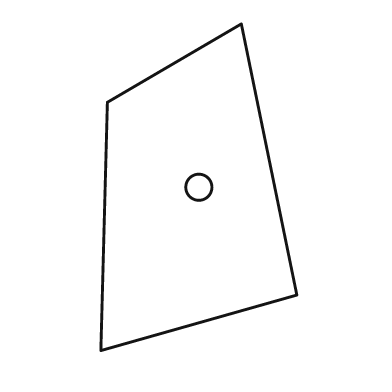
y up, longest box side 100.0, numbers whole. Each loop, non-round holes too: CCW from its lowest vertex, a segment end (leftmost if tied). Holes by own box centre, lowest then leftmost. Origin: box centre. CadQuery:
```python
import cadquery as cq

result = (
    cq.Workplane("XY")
    .moveTo(-30.0, -50.0)
    .lineTo(30.0, -33.0)
    .lineTo(13.0, 50.0)
    .lineTo(-28.0, 26.0)
    .close()
    .moveTo(0.0, 0.0)
    .circle(4.0)
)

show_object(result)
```